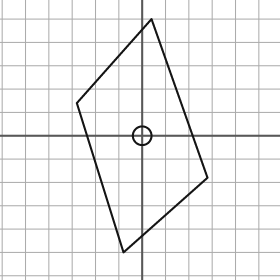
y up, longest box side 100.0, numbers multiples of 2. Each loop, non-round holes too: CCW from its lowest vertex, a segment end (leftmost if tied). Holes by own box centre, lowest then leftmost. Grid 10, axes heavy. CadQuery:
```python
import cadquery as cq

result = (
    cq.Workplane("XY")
    .moveTo(-8.0, -50.0)
    .lineTo(28.0, -18.0)
    .lineTo(4.0, 50.0)
    .lineTo(-28.0, 14.0)
    .close()
    .moveTo(0.0, 0.0)
    .circle(4.0)
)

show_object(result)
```